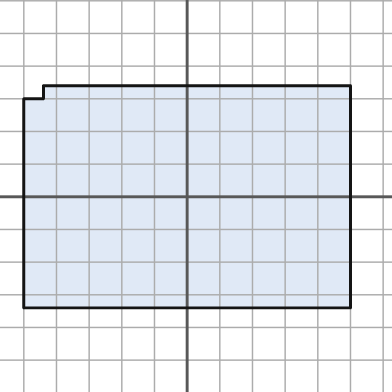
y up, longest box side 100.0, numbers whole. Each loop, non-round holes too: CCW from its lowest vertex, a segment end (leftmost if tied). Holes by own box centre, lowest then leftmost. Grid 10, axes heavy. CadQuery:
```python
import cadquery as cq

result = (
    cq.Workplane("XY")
    .moveTo(-50.0, -34.0)
    .lineTo(50.0, -34.0)
    .lineTo(50.0, 34.0)
    .lineTo(-44.0, 34.0)
    .lineTo(-44.0, 30.0)
    .lineTo(-50.0, 30.0)
    .close()
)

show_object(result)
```